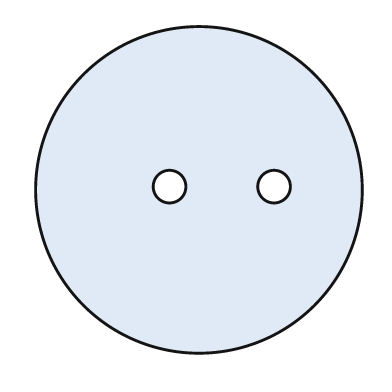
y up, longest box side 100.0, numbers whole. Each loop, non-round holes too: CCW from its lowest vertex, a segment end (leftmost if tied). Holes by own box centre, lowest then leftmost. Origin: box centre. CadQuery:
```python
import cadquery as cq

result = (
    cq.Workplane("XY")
    .moveTo(0.0, 0.0)
    .circle(50.0)
    .moveTo(-9.0, 1.0)
    .circle(5.0)
    .moveTo(23.0, 1.0)
    .circle(5.0)
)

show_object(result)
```